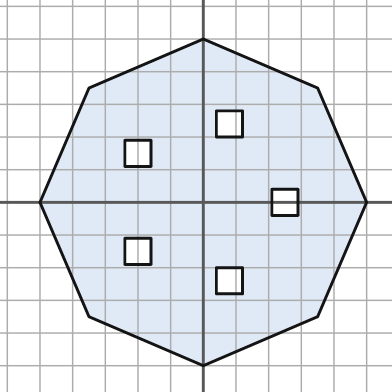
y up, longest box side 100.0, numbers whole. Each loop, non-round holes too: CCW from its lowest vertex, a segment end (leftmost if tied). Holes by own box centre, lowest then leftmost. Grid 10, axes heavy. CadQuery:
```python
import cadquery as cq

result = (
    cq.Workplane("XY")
    .moveTo(0.0, -50.0)
    .lineTo(35.0, -35.0)
    .lineTo(50.0, 0.0)
    .lineTo(35.0, 35.0)
    .lineTo(0.0, 50.0)
    .lineTo(-35.0, 35.0)
    .lineTo(-50.0, 0.0)
    .lineTo(-35.0, -35.0)
    .close()
    .moveTo(4.0, -28.0)
    .lineTo(12.0, -28.0)
    .lineTo(12.0, -20.0)
    .lineTo(4.0, -20.0)
    .close()
    .moveTo(-24.0, -19.0)
    .lineTo(-16.0, -19.0)
    .lineTo(-16.0, -11.0)
    .lineTo(-24.0, -11.0)
    .close()
    .moveTo(21.0, -4.0)
    .lineTo(29.0, -4.0)
    .lineTo(29.0, 4.0)
    .lineTo(21.0, 4.0)
    .close()
    .moveTo(-24.0, 11.0)
    .lineTo(-16.0, 11.0)
    .lineTo(-16.0, 19.0)
    .lineTo(-24.0, 19.0)
    .close()
    .moveTo(4.0, 20.0)
    .lineTo(12.0, 20.0)
    .lineTo(12.0, 28.0)
    .lineTo(4.0, 28.0)
    .close()
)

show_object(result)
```